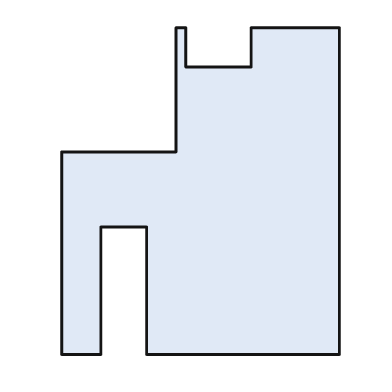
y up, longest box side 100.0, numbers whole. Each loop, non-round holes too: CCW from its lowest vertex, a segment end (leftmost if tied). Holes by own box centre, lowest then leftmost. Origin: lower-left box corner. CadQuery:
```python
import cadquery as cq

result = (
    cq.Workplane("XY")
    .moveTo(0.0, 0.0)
    .lineTo(12.0, 0.0)
    .lineTo(12.0, 39.0)
    .lineTo(26.0, 39.0)
    .lineTo(26.0, 0.0)
    .lineTo(85.0, 0.0)
    .lineTo(85.0, 100.0)
    .lineTo(58.0, 100.0)
    .lineTo(58.0, 88.0)
    .lineTo(38.0, 88.0)
    .lineTo(38.0, 100.0)
    .lineTo(35.0, 100.0)
    .lineTo(35.0, 62.0)
    .lineTo(0.0, 62.0)
    .close()
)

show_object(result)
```